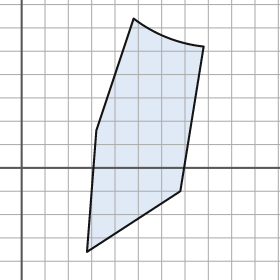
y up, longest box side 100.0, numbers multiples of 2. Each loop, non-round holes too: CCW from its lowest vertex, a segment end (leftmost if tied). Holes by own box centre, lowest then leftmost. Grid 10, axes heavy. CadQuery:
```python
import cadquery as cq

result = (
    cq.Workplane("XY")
    .moveTo(28.0, -36.0)
    .lineTo(68.0, -10.0)
    .lineTo(78.0, 52.0)
    .threePointArc((62.0, 56.0), (48.0, 64.0))
    .lineTo(32.0, 16.0)
    .close()
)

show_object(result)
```